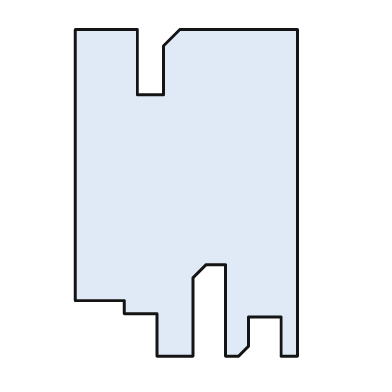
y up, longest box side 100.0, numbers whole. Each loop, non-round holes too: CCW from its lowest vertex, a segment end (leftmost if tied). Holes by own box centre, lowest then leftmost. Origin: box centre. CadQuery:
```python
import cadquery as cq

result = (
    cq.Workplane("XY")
    .moveTo(-9.0, -50.0)
    .lineTo(2.0, -50.0)
    .lineTo(2.0, -26.0)
    .lineTo(6.0, -22.0)
    .lineTo(12.0, -22.0)
    .lineTo(12.0, -50.0)
    .lineTo(16.0, -50.0)
    .lineTo(19.0, -47.0)
    .lineTo(19.0, -38.0)
    .lineTo(29.0, -38.0)
    .lineTo(29.0, -50.0)
    .lineTo(34.0, -50.0)
    .lineTo(34.0, 50.0)
    .lineTo(-2.0, 50.0)
    .lineTo(-7.0, 45.0)
    .lineTo(-7.0, 30.0)
    .lineTo(-15.0, 30.0)
    .lineTo(-15.0, 50.0)
    .lineTo(-34.0, 50.0)
    .lineTo(-34.0, -33.0)
    .lineTo(-19.0, -33.0)
    .lineTo(-19.0, -37.0)
    .lineTo(-9.0, -37.0)
    .close()
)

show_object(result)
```